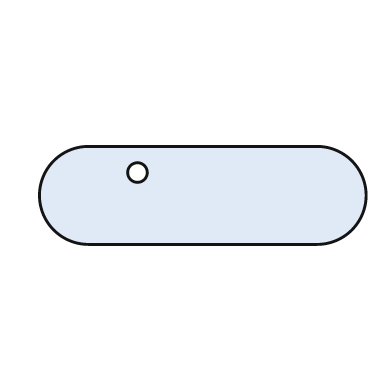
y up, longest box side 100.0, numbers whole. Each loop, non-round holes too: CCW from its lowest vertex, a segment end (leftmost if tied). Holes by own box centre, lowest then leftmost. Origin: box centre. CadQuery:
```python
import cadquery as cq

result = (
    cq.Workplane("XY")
    .moveTo(-35.0, -15.0)
    .lineTo(35.0, -15.0)
    .threePointArc((50.0, 0.0), (35.0, 15.0))
    .lineTo(-35.0, 15.0)
    .threePointArc((-50.0, 0.0), (-35.0, -15.0))
    .close()
    .moveTo(-20.0, 7.0)
    .circle(3.0)
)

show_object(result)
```